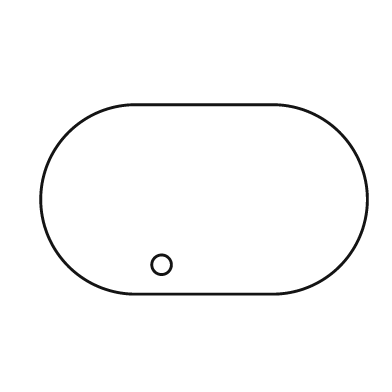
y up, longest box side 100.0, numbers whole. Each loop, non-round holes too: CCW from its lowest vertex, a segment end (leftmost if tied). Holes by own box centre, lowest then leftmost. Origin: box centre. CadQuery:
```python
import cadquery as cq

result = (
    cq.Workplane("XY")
    .moveTo(-21.0, -29.0)
    .lineTo(21.0, -29.0)
    .threePointArc((50.0, 0.0), (21.0, 29.0))
    .lineTo(-21.0, 29.0)
    .threePointArc((-50.0, 0.0), (-21.0, -29.0))
    .close()
    .moveTo(-13.0, -20.0)
    .circle(3.0)
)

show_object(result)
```